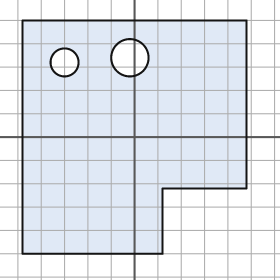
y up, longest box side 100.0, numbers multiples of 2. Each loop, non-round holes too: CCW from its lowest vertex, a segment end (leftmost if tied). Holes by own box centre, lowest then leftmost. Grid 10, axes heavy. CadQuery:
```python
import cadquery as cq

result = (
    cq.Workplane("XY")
    .moveTo(-48.0, -50.0)
    .lineTo(12.0, -50.0)
    .lineTo(12.0, -22.0)
    .lineTo(48.0, -22.0)
    .lineTo(48.0, 50.0)
    .lineTo(-48.0, 50.0)
    .close()
    .moveTo(-30.0, 32.0)
    .circle(6.0)
    .moveTo(-2.0, 34.0)
    .circle(8.0)
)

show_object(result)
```